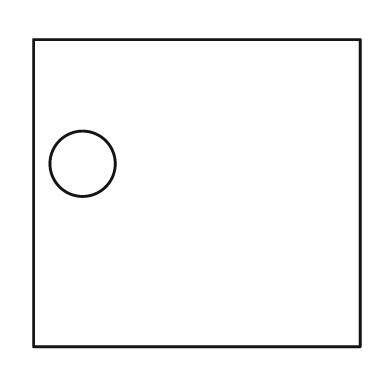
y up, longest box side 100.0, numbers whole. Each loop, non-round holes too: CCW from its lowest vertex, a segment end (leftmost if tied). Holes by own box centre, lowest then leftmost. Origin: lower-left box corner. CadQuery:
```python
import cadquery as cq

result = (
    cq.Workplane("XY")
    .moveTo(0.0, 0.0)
    .lineTo(100.0, 0.0)
    .lineTo(100.0, 94.0)
    .lineTo(0.0, 94.0)
    .close()
    .moveTo(15.0, 56.0)
    .circle(10.0)
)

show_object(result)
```